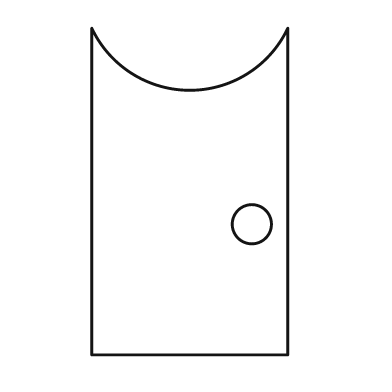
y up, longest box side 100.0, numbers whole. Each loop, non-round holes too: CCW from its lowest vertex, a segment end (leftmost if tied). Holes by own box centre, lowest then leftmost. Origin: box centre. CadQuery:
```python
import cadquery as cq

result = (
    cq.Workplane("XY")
    .moveTo(-30.0, -50.0)
    .lineTo(30.0, -50.0)
    .lineTo(30.0, 50.0)
    .threePointArc((0.0, 31.0), (-30.0, 50.0))
    .close()
    .moveTo(19.0, -10.0)
    .circle(6.0)
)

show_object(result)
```